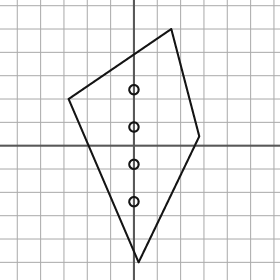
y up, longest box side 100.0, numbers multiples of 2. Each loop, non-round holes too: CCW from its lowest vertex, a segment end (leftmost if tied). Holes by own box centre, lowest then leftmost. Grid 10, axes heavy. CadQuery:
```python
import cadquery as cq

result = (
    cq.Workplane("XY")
    .moveTo(2.0, -50.0)
    .lineTo(28.0, 4.0)
    .lineTo(16.0, 50.0)
    .lineTo(-28.0, 20.0)
    .close()
    .moveTo(0.0, -24.0)
    .circle(2.0)
    .moveTo(0.0, -8.0)
    .circle(2.0)
    .moveTo(0.0, 8.0)
    .circle(2.0)
    .moveTo(0.0, 24.0)
    .circle(2.0)
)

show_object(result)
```